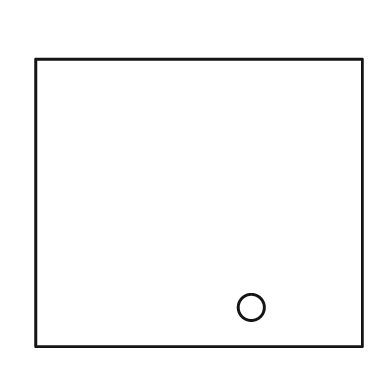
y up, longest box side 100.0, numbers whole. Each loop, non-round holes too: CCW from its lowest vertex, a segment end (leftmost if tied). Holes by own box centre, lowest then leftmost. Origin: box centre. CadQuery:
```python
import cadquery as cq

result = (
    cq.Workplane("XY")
    .moveTo(-50.0, -44.0)
    .lineTo(50.0, -44.0)
    .lineTo(50.0, 44.0)
    .lineTo(-50.0, 44.0)
    .close()
    .moveTo(16.0, -32.0)
    .circle(4.0)
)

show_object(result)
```